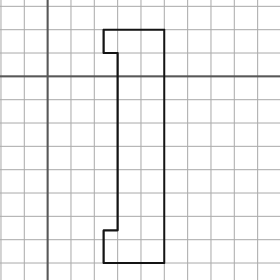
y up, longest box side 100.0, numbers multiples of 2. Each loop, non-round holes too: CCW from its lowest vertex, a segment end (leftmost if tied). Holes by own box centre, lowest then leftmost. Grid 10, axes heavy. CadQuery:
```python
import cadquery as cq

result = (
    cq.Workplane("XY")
    .moveTo(24.0, -80.0)
    .lineTo(50.0, -80.0)
    .lineTo(50.0, 20.0)
    .lineTo(24.0, 20.0)
    .lineTo(24.0, 10.0)
    .lineTo(30.0, 10.0)
    .lineTo(30.0, -66.0)
    .lineTo(24.0, -66.0)
    .close()
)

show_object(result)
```